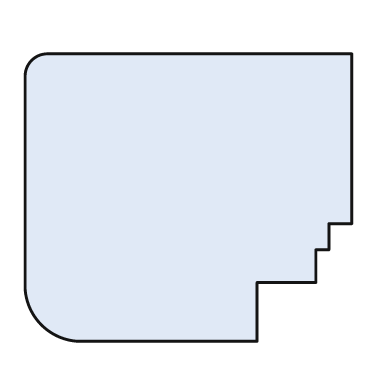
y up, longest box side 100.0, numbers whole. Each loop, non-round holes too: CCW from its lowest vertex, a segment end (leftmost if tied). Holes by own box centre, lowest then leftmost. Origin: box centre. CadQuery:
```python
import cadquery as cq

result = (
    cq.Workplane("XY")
    .moveTo(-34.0, -44.0)
    .lineTo(21.0, -44.0)
    .lineTo(21.0, -26.0)
    .lineTo(39.0, -26.0)
    .lineTo(39.0, -16.0)
    .lineTo(43.0, -16.0)
    .lineTo(43.0, -8.0)
    .lineTo(50.0, -8.0)
    .lineTo(50.0, 44.0)
    .lineTo(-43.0, 44.0)
    .threePointArc((-48.0, 42.0), (-50.0, 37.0))
    .lineTo(-50.0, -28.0)
    .threePointArc((-45.0, -39.0), (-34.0, -44.0))
    .close()
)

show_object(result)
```